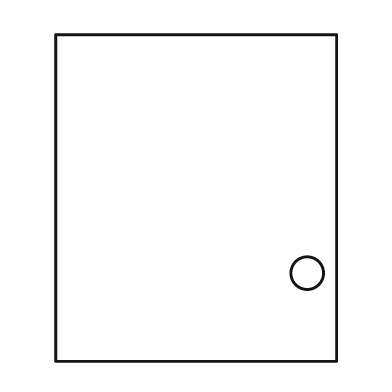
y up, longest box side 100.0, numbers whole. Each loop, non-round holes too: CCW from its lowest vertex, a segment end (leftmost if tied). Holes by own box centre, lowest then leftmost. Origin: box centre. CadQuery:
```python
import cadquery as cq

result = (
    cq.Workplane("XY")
    .moveTo(-43.0, -50.0)
    .lineTo(43.0, -50.0)
    .lineTo(43.0, 50.0)
    .lineTo(-43.0, 50.0)
    .close()
    .moveTo(34.0, -23.0)
    .circle(5.0)
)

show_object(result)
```